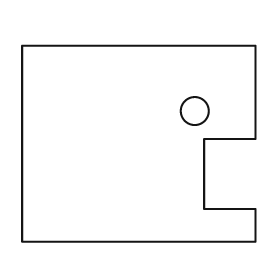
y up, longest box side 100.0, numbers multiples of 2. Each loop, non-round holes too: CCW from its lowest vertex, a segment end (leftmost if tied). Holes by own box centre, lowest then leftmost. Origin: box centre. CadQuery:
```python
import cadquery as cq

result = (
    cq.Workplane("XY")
    .moveTo(-50.0, -42.0)
    .lineTo(50.0, -42.0)
    .lineTo(50.0, -28.0)
    .lineTo(28.0, -28.0)
    .lineTo(28.0, 2.0)
    .lineTo(50.0, 2.0)
    .lineTo(50.0, 42.0)
    .lineTo(-50.0, 42.0)
    .close()
    .moveTo(24.0, 14.0)
    .circle(6.0)
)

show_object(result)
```